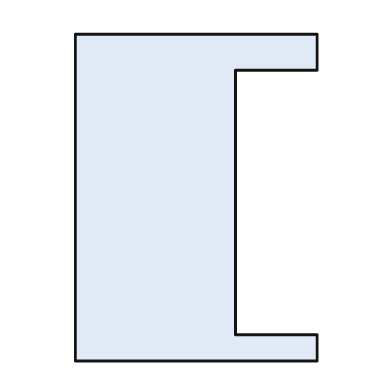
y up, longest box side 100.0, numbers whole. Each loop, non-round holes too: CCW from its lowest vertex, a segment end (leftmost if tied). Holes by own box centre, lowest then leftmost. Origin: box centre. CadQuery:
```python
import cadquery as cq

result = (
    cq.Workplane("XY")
    .moveTo(-37.0, -50.0)
    .lineTo(37.0, -50.0)
    .lineTo(37.0, -42.0)
    .lineTo(12.0, -42.0)
    .lineTo(12.0, 39.0)
    .lineTo(37.0, 39.0)
    .lineTo(37.0, 50.0)
    .lineTo(-37.0, 50.0)
    .close()
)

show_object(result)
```